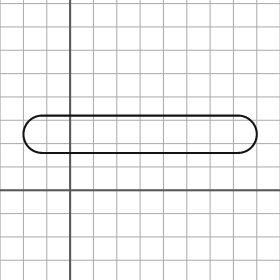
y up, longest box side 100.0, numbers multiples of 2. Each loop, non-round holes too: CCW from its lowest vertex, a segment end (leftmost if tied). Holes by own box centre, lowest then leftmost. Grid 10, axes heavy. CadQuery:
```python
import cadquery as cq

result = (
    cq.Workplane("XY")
    .moveTo(-12.0, 16.0)
    .lineTo(72.0, 16.0)
    .threePointArc((80.0, 24.0), (72.0, 32.0))
    .lineTo(-12.0, 32.0)
    .threePointArc((-20.0, 24.0), (-12.0, 16.0))
    .close()
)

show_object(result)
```